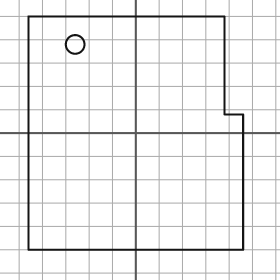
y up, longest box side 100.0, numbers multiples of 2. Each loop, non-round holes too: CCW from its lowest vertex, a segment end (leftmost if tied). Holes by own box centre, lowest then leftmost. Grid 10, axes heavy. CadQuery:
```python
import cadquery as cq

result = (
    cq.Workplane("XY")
    .moveTo(-46.0, -50.0)
    .lineTo(46.0, -50.0)
    .lineTo(46.0, 8.0)
    .lineTo(38.0, 8.0)
    .lineTo(38.0, 50.0)
    .lineTo(-46.0, 50.0)
    .close()
    .moveTo(-26.0, 38.0)
    .circle(4.0)
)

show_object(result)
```